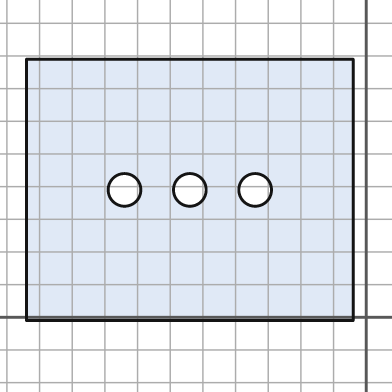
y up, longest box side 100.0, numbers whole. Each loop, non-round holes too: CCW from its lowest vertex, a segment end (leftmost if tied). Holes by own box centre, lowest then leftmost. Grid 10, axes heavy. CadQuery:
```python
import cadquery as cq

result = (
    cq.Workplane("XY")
    .moveTo(-104.0, -1.0)
    .lineTo(-4.0, -1.0)
    .lineTo(-4.0, 79.0)
    .lineTo(-104.0, 79.0)
    .close()
    .moveTo(-74.0, 39.0)
    .circle(5.0)
    .moveTo(-54.0, 39.0)
    .circle(5.0)
    .moveTo(-34.0, 39.0)
    .circle(5.0)
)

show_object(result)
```